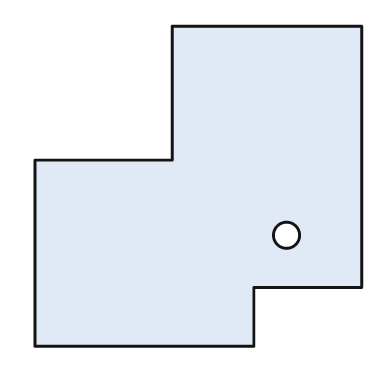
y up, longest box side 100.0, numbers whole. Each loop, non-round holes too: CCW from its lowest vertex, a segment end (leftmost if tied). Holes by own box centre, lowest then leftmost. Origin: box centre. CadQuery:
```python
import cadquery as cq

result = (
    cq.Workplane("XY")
    .moveTo(-50.0, -49.0)
    .lineTo(17.0, -49.0)
    .lineTo(17.0, -31.0)
    .lineTo(50.0, -31.0)
    .lineTo(50.0, 49.0)
    .lineTo(-8.0, 49.0)
    .lineTo(-8.0, 8.0)
    .lineTo(-50.0, 8.0)
    .close()
    .moveTo(27.0, -15.0)
    .circle(4.0)
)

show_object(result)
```